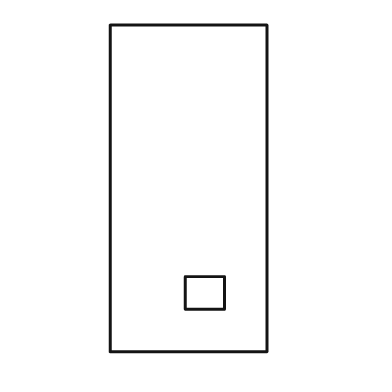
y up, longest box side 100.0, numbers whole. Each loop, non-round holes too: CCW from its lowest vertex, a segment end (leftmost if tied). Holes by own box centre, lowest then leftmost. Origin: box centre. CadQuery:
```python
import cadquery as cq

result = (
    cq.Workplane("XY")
    .moveTo(-24.0, -50.0)
    .lineTo(24.0, -50.0)
    .lineTo(24.0, 50.0)
    .lineTo(-24.0, 50.0)
    .close()
    .moveTo(-1.0, -37.0)
    .lineTo(11.0, -37.0)
    .lineTo(11.0, -27.0)
    .lineTo(-1.0, -27.0)
    .close()
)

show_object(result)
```